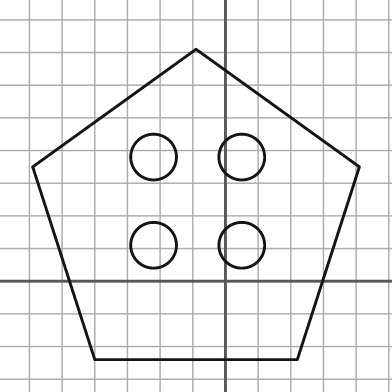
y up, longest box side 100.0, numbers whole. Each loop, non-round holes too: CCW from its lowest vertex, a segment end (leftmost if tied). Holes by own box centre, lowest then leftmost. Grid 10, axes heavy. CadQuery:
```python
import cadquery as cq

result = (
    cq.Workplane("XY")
    .moveTo(-40.0, -24.0)
    .lineTo(22.0, -24.0)
    .lineTo(41.0, 35.0)
    .lineTo(-9.0, 71.0)
    .lineTo(-59.0, 35.0)
    .close()
    .moveTo(-22.0, 11.0)
    .circle(7.0)
    .moveTo(5.0, 11.0)
    .circle(7.0)
    .moveTo(-22.0, 38.0)
    .circle(7.0)
    .moveTo(5.0, 38.0)
    .circle(7.0)
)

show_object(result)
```